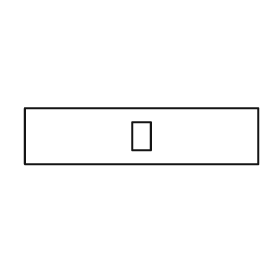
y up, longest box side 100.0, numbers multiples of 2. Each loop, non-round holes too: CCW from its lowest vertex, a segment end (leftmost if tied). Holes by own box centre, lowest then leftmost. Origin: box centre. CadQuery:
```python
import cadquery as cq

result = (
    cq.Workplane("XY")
    .moveTo(-50.0, -12.0)
    .lineTo(50.0, -12.0)
    .lineTo(50.0, 12.0)
    .lineTo(-50.0, 12.0)
    .close()
    .moveTo(-4.0, -6.0)
    .lineTo(4.0, -6.0)
    .lineTo(4.0, 6.0)
    .lineTo(-4.0, 6.0)
    .close()
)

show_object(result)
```